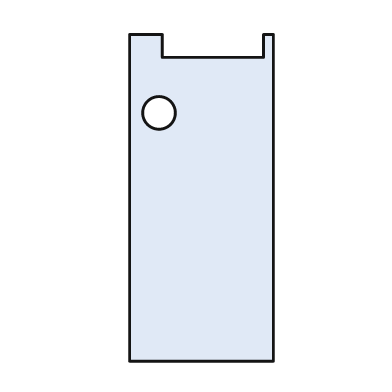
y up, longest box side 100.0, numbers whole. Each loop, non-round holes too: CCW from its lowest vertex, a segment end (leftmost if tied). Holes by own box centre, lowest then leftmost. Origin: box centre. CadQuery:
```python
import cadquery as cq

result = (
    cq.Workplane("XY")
    .moveTo(-22.0, -50.0)
    .lineTo(22.0, -50.0)
    .lineTo(22.0, 50.0)
    .lineTo(19.0, 50.0)
    .lineTo(19.0, 43.0)
    .lineTo(-12.0, 43.0)
    .lineTo(-12.0, 50.0)
    .lineTo(-22.0, 50.0)
    .close()
    .moveTo(-13.0, 26.0)
    .circle(5.0)
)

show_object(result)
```